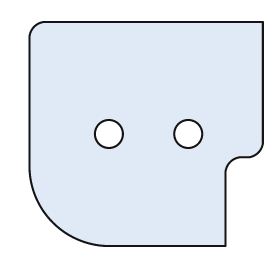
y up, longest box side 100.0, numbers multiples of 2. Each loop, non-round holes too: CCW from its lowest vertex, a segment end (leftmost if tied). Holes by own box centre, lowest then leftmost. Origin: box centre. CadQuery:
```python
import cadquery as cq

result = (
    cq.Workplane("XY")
    .moveTo(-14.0, -48.0)
    .lineTo(34.0, -48.0)
    .lineTo(34.0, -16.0)
    .threePointArc((36.0, -12.0), (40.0, -10.0))
    .lineTo(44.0, -10.0)
    .threePointArc((48.0, -8.0), (50.0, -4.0))
    .lineTo(50.0, 48.0)
    .lineTo(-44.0, 48.0)
    .threePointArc((-48.0, 46.0), (-50.0, 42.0))
    .lineTo(-50.0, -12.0)
    .threePointArc((-40.0, -38.0), (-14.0, -48.0))
    .close()
    .moveTo(-16.0, 0.0)
    .circle(6.0)
    .moveTo(18.0, 0.0)
    .circle(6.0)
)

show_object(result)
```